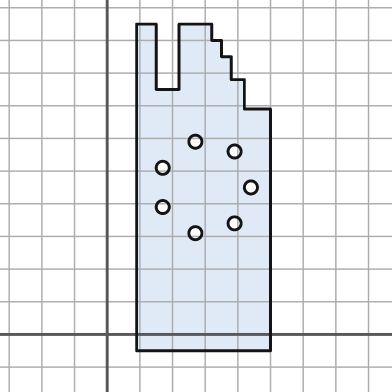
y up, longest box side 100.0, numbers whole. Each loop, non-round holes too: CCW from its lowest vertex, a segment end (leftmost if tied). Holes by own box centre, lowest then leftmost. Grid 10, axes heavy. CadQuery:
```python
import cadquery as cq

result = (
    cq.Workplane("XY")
    .moveTo(9.0, -5.0)
    .lineTo(50.0, -5.0)
    .lineTo(50.0, 69.0)
    .lineTo(42.0, 69.0)
    .lineTo(42.0, 78.0)
    .lineTo(38.0, 78.0)
    .lineTo(38.0, 85.0)
    .lineTo(35.0, 85.0)
    .lineTo(35.0, 90.0)
    .lineTo(32.0, 90.0)
    .lineTo(32.0, 95.0)
    .lineTo(22.0, 95.0)
    .lineTo(22.0, 75.0)
    .lineTo(15.0, 75.0)
    .lineTo(15.0, 95.0)
    .lineTo(9.0, 95.0)
    .close()
    .moveTo(27.0, 31.0)
    .circle(2.0)
    .moveTo(39.0, 34.0)
    .circle(2.0)
    .moveTo(17.0, 39.0)
    .circle(2.0)
    .moveTo(44.0, 45.0)
    .circle(2.0)
    .moveTo(17.0, 51.0)
    .circle(2.0)
    .moveTo(39.0, 56.0)
    .circle(2.0)
    .moveTo(27.0, 59.0)
    .circle(2.0)
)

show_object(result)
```